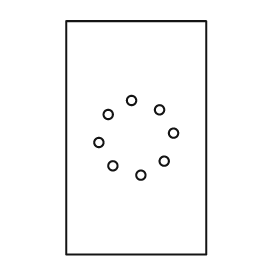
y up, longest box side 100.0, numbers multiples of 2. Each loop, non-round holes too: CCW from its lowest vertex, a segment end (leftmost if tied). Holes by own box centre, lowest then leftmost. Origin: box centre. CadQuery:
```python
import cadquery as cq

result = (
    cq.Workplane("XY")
    .moveTo(-30.0, -50.0)
    .lineTo(30.0, -50.0)
    .lineTo(30.0, 50.0)
    .lineTo(-30.0, 50.0)
    .close()
    .moveTo(2.0, -16.0)
    .circle(2.0)
    .moveTo(-10.0, -12.0)
    .circle(2.0)
    .moveTo(12.0, -10.0)
    .circle(2.0)
    .moveTo(-16.0, -2.0)
    .circle(2.0)
    .moveTo(16.0, 2.0)
    .circle(2.0)
    .moveTo(-12.0, 10.0)
    .circle(2.0)
    .moveTo(10.0, 12.0)
    .circle(2.0)
    .moveTo(-2.0, 16.0)
    .circle(2.0)
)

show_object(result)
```